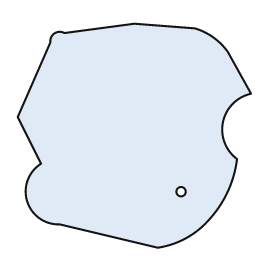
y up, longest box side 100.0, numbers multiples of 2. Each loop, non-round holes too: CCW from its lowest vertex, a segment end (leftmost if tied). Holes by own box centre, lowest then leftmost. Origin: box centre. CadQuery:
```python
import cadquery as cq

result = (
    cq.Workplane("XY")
    .moveTo(10.0, -48.0)
    .threePointArc((22.0, -44.0), (32.0, -36.0))
    .threePointArc((40.0, -24.0), (44.0, -10.0))
    .threePointArc((38.0, 6.0), (50.0, 18.0))
    .lineTo(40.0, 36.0)
    .threePointArc((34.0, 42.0), (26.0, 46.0))
    .lineTo(0.0, 48.0)
    .lineTo(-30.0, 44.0)
    .threePointArc((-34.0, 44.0), (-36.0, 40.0))
    .lineTo(-50.0, 8.0)
    .lineTo(-40.0, -12.0)
    .threePointArc((-46.0, -28.0), (-32.0, -38.0))
    .close()
    .moveTo(20.0, -24.0)
    .circle(2.0)
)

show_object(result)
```